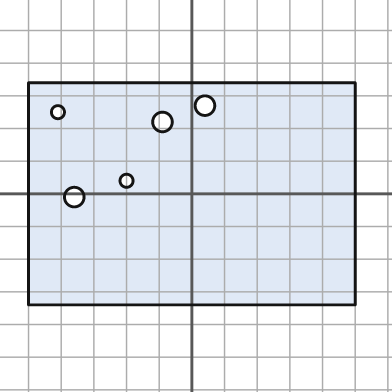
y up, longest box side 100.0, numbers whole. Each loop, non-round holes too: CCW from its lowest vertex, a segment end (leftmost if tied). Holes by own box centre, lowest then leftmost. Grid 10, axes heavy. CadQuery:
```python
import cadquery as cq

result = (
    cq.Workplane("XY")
    .moveTo(-50.0, -34.0)
    .lineTo(50.0, -34.0)
    .lineTo(50.0, 34.0)
    .lineTo(-50.0, 34.0)
    .close()
    .moveTo(-36.0, -1.0)
    .circle(3.0)
    .moveTo(-20.0, 4.0)
    .circle(2.0)
    .moveTo(-9.0, 22.0)
    .circle(3.0)
    .moveTo(-41.0, 25.0)
    .circle(2.0)
    .moveTo(4.0, 27.0)
    .circle(3.0)
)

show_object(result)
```